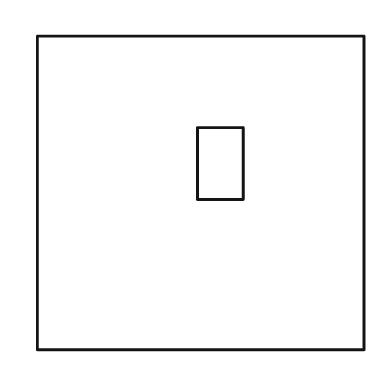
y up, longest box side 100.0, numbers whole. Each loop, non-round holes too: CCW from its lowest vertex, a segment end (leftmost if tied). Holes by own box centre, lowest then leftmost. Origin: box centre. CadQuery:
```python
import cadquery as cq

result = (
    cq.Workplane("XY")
    .moveTo(-50.0, -48.0)
    .lineTo(50.0, -48.0)
    .lineTo(50.0, 48.0)
    .lineTo(-50.0, 48.0)
    .close()
    .moveTo(-1.0, -2.0)
    .lineTo(13.0, -2.0)
    .lineTo(13.0, 20.0)
    .lineTo(-1.0, 20.0)
    .close()
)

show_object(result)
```